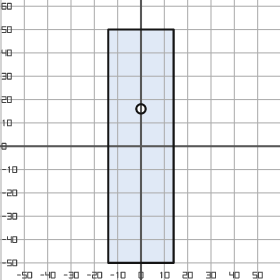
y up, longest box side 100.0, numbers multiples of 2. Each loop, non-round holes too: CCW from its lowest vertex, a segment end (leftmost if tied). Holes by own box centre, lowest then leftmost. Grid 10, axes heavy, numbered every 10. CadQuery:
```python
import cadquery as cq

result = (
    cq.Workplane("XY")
    .moveTo(-14.0, -50.0)
    .lineTo(14.0, -50.0)
    .lineTo(14.0, 50.0)
    .lineTo(-14.0, 50.0)
    .close()
    .moveTo(0.0, 16.0)
    .circle(2.0)
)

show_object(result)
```